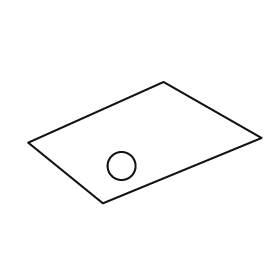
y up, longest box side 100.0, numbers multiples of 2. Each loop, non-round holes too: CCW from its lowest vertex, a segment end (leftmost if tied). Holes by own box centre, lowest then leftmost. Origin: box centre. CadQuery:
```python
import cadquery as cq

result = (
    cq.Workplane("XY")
    .moveTo(-18.0, -26.0)
    .lineTo(50.0, 2.0)
    .lineTo(8.0, 26.0)
    .lineTo(-50.0, 0.0)
    .close()
    .moveTo(-10.0, -10.0)
    .circle(6.0)
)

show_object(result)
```